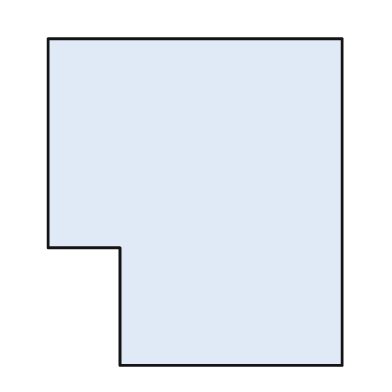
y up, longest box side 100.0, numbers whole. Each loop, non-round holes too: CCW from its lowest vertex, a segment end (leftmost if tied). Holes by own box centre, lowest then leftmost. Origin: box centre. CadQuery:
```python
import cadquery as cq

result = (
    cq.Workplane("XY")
    .moveTo(-23.0, -50.0)
    .lineTo(45.0, -50.0)
    .lineTo(45.0, 50.0)
    .lineTo(-45.0, 50.0)
    .lineTo(-45.0, -14.0)
    .lineTo(-23.0, -14.0)
    .close()
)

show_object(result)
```